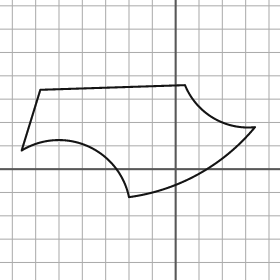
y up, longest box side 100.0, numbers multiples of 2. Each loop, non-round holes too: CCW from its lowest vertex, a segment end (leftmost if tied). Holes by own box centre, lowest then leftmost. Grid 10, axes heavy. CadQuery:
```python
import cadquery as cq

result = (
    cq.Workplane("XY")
    .moveTo(-20.0, -12.0)
    .threePointArc((10.0, -2.0), (34.0, 18.0))
    .threePointArc((16.0, 22.0), (4.0, 36.0))
    .lineTo(-58.0, 34.0)
    .lineTo(-66.0, 8.0)
    .threePointArc((-38.0, 10.0), (-20.0, -12.0))
    .close()
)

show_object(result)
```